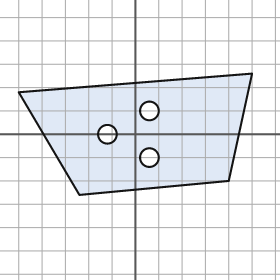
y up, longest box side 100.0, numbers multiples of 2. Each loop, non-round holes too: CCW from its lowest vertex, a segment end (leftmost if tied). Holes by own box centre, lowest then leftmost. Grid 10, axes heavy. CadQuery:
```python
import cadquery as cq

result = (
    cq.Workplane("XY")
    .moveTo(-24.0, -26.0)
    .lineTo(40.0, -20.0)
    .lineTo(50.0, 26.0)
    .lineTo(-50.0, 18.0)
    .close()
    .moveTo(6.0, -10.0)
    .circle(4.0)
    .moveTo(-12.0, 0.0)
    .circle(4.0)
    .moveTo(6.0, 10.0)
    .circle(4.0)
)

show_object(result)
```